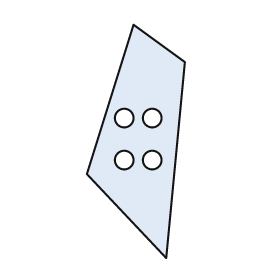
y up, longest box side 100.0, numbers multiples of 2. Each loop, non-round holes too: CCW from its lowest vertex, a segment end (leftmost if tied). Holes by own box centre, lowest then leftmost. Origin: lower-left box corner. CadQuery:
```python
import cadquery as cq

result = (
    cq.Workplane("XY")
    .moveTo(34.0, 0.0)
    .lineTo(42.0, 84.0)
    .lineTo(20.0, 100.0)
    .lineTo(0.0, 36.0)
    .close()
    .moveTo(16.0, 42.0)
    .circle(4.0)
    .moveTo(28.0, 42.0)
    .circle(4.0)
    .moveTo(16.0, 60.0)
    .circle(4.0)
    .moveTo(28.0, 60.0)
    .circle(4.0)
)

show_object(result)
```